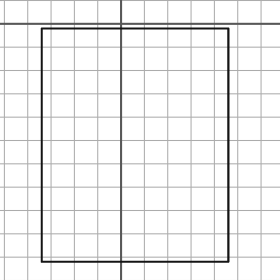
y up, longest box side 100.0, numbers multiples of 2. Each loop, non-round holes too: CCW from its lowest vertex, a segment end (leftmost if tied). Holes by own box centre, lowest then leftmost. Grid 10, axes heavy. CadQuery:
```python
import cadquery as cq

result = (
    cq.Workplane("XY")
    .moveTo(-34.0, -102.0)
    .lineTo(46.0, -102.0)
    .lineTo(46.0, -2.0)
    .lineTo(-34.0, -2.0)
    .close()
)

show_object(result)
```